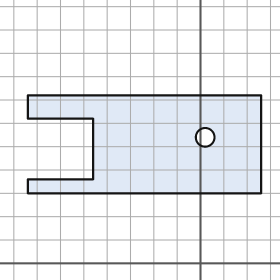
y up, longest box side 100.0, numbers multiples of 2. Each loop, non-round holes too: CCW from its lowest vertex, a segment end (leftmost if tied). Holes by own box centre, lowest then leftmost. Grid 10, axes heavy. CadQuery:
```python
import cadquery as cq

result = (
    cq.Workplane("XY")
    .moveTo(-74.0, 30.0)
    .lineTo(26.0, 30.0)
    .lineTo(26.0, 72.0)
    .lineTo(-74.0, 72.0)
    .lineTo(-74.0, 62.0)
    .lineTo(-46.0, 62.0)
    .lineTo(-46.0, 36.0)
    .lineTo(-74.0, 36.0)
    .close()
    .moveTo(2.0, 54.0)
    .circle(4.0)
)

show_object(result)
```